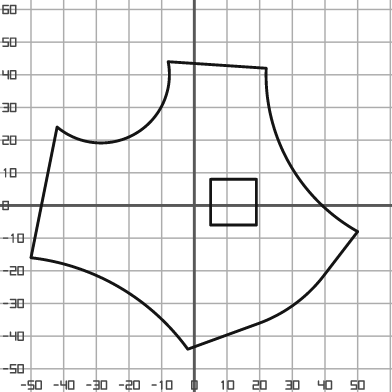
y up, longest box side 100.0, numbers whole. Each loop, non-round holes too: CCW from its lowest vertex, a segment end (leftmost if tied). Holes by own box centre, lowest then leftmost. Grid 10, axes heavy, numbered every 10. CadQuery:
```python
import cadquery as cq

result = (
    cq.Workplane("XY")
    .moveTo(-2.0, -44.0)
    .lineTo(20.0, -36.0)
    .threePointArc((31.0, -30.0), (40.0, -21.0))
    .lineTo(50.0, -8.0)
    .threePointArc((29.0, 13.0), (22.0, 42.0))
    .lineTo(-8.0, 44.0)
    .threePointArc((-18.0, 22.0), (-42.0, 24.0))
    .lineTo(-50.0, -16.0)
    .threePointArc((-23.0, -25.0), (-2.0, -44.0))
    .close()
    .moveTo(5.0, -6.0)
    .lineTo(19.0, -6.0)
    .lineTo(19.0, 8.0)
    .lineTo(5.0, 8.0)
    .close()
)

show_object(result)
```